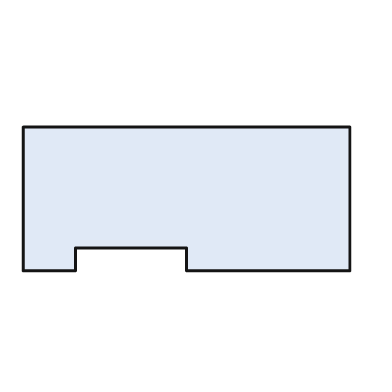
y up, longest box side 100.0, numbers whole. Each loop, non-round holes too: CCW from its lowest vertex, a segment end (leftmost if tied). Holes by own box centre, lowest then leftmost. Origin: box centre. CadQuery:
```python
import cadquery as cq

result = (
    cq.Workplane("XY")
    .moveTo(-50.0, -22.0)
    .lineTo(-34.0, -22.0)
    .lineTo(-34.0, -15.0)
    .lineTo(0.0, -15.0)
    .lineTo(0.0, -22.0)
    .lineTo(50.0, -22.0)
    .lineTo(50.0, 22.0)
    .lineTo(-50.0, 22.0)
    .close()
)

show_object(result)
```